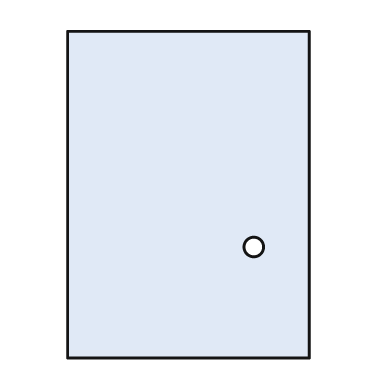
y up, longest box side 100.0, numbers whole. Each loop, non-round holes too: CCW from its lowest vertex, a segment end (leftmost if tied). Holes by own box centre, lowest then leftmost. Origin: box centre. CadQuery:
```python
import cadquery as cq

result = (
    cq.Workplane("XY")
    .moveTo(-37.0, -50.0)
    .lineTo(37.0, -50.0)
    .lineTo(37.0, 50.0)
    .lineTo(-37.0, 50.0)
    .close()
    .moveTo(20.0, -16.0)
    .circle(3.0)
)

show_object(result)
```